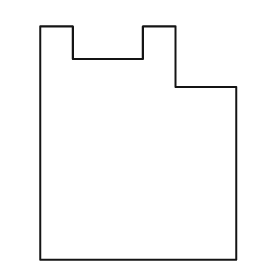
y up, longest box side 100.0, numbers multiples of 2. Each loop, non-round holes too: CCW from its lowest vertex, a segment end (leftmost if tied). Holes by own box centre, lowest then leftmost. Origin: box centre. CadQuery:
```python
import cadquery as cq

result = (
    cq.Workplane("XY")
    .moveTo(-42.0, -50.0)
    .lineTo(42.0, -50.0)
    .lineTo(42.0, 24.0)
    .lineTo(16.0, 24.0)
    .lineTo(16.0, 50.0)
    .lineTo(2.0, 50.0)
    .lineTo(2.0, 36.0)
    .lineTo(-28.0, 36.0)
    .lineTo(-28.0, 50.0)
    .lineTo(-42.0, 50.0)
    .close()
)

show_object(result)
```